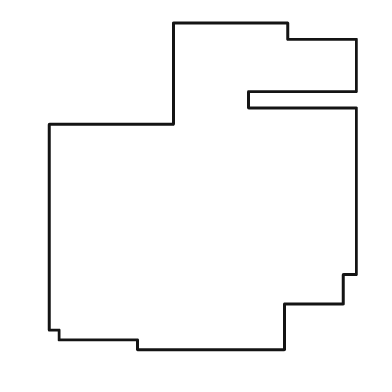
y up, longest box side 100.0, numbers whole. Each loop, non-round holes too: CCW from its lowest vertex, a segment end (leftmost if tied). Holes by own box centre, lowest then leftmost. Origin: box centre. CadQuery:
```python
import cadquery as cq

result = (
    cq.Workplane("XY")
    .moveTo(-20.0, -50.0)
    .lineTo(25.0, -50.0)
    .lineTo(25.0, -36.0)
    .lineTo(43.0, -36.0)
    .lineTo(43.0, -27.0)
    .lineTo(47.0, -27.0)
    .lineTo(47.0, 24.0)
    .lineTo(14.0, 24.0)
    .lineTo(14.0, 29.0)
    .lineTo(47.0, 29.0)
    .lineTo(47.0, 45.0)
    .lineTo(26.0, 45.0)
    .lineTo(26.0, 50.0)
    .lineTo(-9.0, 50.0)
    .lineTo(-9.0, 19.0)
    .lineTo(-47.0, 19.0)
    .lineTo(-47.0, -44.0)
    .lineTo(-44.0, -44.0)
    .lineTo(-44.0, -47.0)
    .lineTo(-20.0, -47.0)
    .close()
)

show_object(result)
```